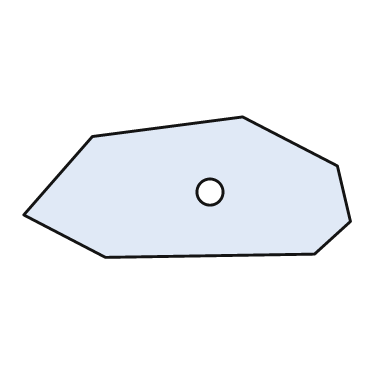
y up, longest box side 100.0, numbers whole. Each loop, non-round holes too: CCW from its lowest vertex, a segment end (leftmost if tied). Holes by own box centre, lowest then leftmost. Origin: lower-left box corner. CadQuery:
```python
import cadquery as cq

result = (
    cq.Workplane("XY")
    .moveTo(25.0, 0.0)
    .lineTo(89.0, 1.0)
    .lineTo(100.0, 11.0)
    .lineTo(96.0, 28.0)
    .lineTo(67.0, 43.0)
    .lineTo(21.0, 37.0)
    .lineTo(0.0, 13.0)
    .close()
    .moveTo(57.0, 20.0)
    .circle(4.0)
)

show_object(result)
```